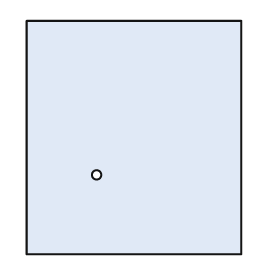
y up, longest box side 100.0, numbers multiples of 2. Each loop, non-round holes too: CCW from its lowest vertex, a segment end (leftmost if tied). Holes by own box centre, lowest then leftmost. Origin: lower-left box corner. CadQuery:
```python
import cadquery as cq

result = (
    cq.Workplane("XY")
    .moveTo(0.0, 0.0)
    .lineTo(92.0, 0.0)
    .lineTo(92.0, 100.0)
    .lineTo(0.0, 100.0)
    .close()
    .moveTo(30.0, 34.0)
    .circle(2.0)
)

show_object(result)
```